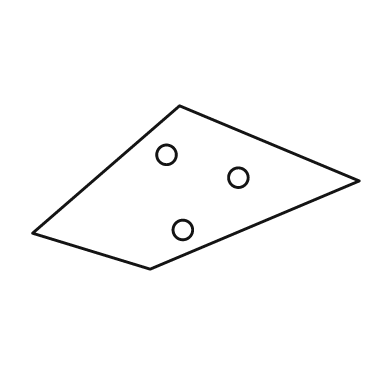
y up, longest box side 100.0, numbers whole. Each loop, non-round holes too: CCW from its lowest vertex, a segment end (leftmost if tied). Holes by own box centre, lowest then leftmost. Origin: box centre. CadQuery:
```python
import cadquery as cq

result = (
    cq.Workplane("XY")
    .moveTo(-14.0, -25.0)
    .lineTo(50.0, 2.0)
    .lineTo(-5.0, 25.0)
    .lineTo(-50.0, -14.0)
    .close()
    .moveTo(-4.0, -13.0)
    .circle(3.0)
    .moveTo(13.0, 3.0)
    .circle(3.0)
    .moveTo(-9.0, 10.0)
    .circle(3.0)
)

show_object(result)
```